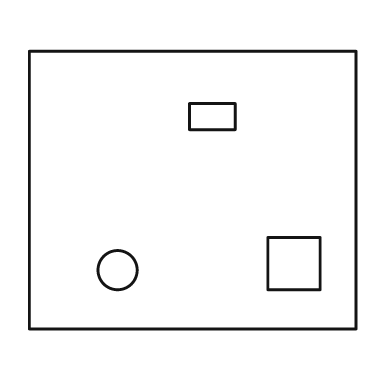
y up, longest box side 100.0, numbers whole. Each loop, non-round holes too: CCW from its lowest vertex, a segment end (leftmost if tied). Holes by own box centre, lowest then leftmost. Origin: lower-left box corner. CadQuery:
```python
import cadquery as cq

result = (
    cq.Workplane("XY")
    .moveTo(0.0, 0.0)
    .lineTo(100.0, 0.0)
    .lineTo(100.0, 85.0)
    .lineTo(0.0, 85.0)
    .close()
    .moveTo(27.0, 18.0)
    .circle(6.0)
    .moveTo(73.0, 12.0)
    .lineTo(89.0, 12.0)
    .lineTo(89.0, 28.0)
    .lineTo(73.0, 28.0)
    .close()
    .moveTo(49.0, 61.0)
    .lineTo(63.0, 61.0)
    .lineTo(63.0, 69.0)
    .lineTo(49.0, 69.0)
    .close()
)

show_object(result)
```